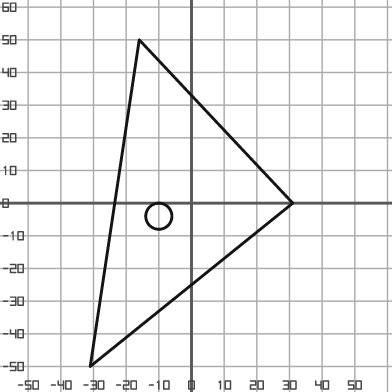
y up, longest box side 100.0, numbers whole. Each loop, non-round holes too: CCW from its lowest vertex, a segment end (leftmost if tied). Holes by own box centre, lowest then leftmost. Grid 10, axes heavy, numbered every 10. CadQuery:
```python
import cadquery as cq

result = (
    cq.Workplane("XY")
    .moveTo(-31.0, -50.0)
    .lineTo(31.0, 0.0)
    .lineTo(-16.0, 50.0)
    .close()
    .moveTo(-10.0, -4.0)
    .circle(4.0)
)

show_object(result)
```